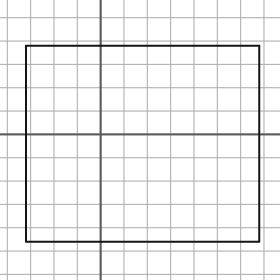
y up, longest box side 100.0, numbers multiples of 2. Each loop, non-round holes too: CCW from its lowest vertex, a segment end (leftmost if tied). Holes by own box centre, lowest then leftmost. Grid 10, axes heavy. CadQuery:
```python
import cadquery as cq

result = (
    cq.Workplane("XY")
    .moveTo(-32.0, -46.0)
    .lineTo(68.0, -46.0)
    .lineTo(68.0, 38.0)
    .lineTo(-32.0, 38.0)
    .close()
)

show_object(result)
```